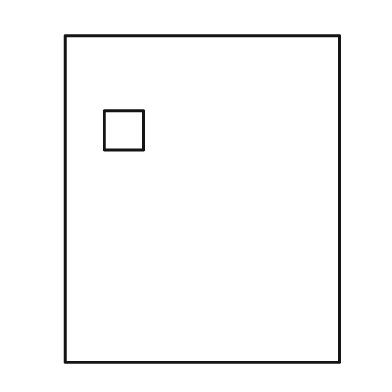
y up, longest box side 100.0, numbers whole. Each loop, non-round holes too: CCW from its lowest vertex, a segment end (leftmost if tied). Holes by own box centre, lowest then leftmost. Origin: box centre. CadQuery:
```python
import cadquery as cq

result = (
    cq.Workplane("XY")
    .moveTo(-42.0, -50.0)
    .lineTo(42.0, -50.0)
    .lineTo(42.0, 50.0)
    .lineTo(-42.0, 50.0)
    .close()
    .moveTo(-30.0, 15.0)
    .lineTo(-18.0, 15.0)
    .lineTo(-18.0, 27.0)
    .lineTo(-30.0, 27.0)
    .close()
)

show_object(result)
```